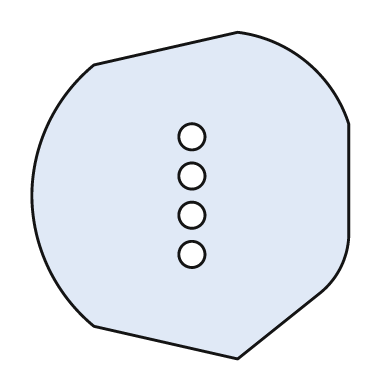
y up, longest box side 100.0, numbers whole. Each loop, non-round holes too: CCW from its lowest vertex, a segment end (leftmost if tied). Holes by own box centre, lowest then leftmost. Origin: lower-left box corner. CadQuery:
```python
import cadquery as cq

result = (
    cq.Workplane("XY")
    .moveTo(63.0, 0.0)
    .lineTo(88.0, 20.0)
    .threePointArc((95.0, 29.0), (97.0, 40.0))
    .lineTo(97.0, 72.0)
    .threePointArc((84.0, 91.0), (63.0, 100.0))
    .lineTo(19.0, 90.0)
    .threePointArc((5.0, 72.0), (0.0, 50.0))
    .threePointArc((5.0, 28.0), (19.0, 10.0))
    .close()
    .moveTo(49.0, 32.0)
    .circle(4.0)
    .moveTo(49.0, 44.0)
    .circle(4.0)
    .moveTo(49.0, 56.0)
    .circle(4.0)
    .moveTo(49.0, 68.0)
    .circle(4.0)
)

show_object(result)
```